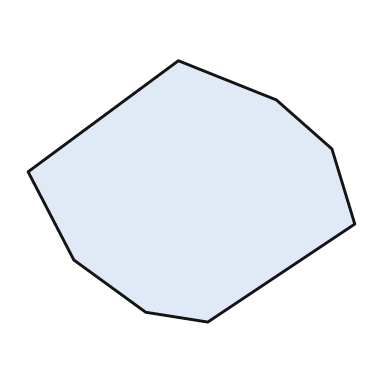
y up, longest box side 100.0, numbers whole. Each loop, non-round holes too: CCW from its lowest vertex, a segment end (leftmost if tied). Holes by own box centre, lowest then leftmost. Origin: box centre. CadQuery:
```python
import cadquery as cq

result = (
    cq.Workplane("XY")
    .moveTo(5.0, -40.0)
    .lineTo(50.0, -10.0)
    .lineTo(43.0, 13.0)
    .lineTo(26.0, 28.0)
    .lineTo(-4.0, 40.0)
    .lineTo(-50.0, 6.0)
    .lineTo(-36.0, -21.0)
    .lineTo(-14.0, -37.0)
    .close()
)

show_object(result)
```